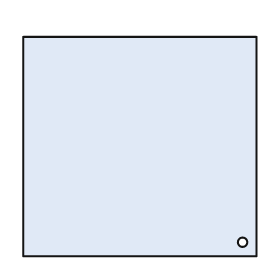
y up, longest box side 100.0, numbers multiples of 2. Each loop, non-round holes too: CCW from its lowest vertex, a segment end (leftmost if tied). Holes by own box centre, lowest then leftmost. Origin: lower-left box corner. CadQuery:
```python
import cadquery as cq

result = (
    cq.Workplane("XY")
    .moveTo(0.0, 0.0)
    .lineTo(100.0, 0.0)
    .lineTo(100.0, 94.0)
    .lineTo(0.0, 94.0)
    .close()
    .moveTo(94.0, 6.0)
    .circle(2.0)
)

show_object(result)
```